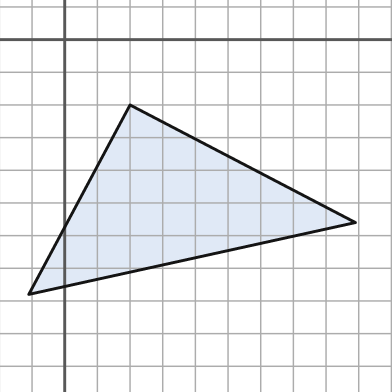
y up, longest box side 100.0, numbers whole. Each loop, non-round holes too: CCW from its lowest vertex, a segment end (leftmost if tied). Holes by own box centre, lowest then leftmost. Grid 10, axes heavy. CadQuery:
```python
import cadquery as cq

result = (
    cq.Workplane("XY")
    .moveTo(-11.0, -78.0)
    .lineTo(89.0, -56.0)
    .lineTo(20.0, -20.0)
    .close()
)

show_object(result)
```